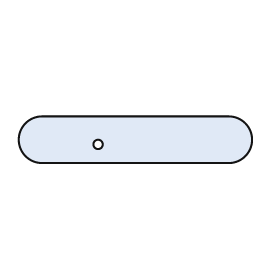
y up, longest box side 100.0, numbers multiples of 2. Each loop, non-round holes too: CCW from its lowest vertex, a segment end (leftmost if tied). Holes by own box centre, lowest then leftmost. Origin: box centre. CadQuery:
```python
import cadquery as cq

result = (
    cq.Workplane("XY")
    .moveTo(-40.0, -10.0)
    .lineTo(40.0, -10.0)
    .threePointArc((50.0, 0.0), (40.0, 10.0))
    .lineTo(-40.0, 10.0)
    .threePointArc((-50.0, 0.0), (-40.0, -10.0))
    .close()
    .moveTo(-16.0, -2.0)
    .circle(2.0)
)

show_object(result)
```